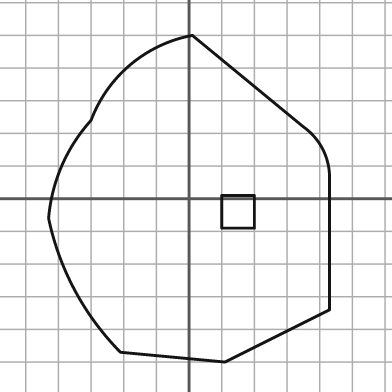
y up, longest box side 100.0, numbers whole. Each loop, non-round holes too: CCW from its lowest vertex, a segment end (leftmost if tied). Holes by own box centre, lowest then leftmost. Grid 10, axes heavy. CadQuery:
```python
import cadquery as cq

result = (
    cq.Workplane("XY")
    .moveTo(11.0, -50.0)
    .lineTo(43.0, -34.0)
    .lineTo(43.0, 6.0)
    .threePointArc((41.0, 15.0), (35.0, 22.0))
    .lineTo(1.0, 50.0)
    .threePointArc((-18.0, 41.0), (-30.0, 24.0))
    .threePointArc((-39.0, 10.0), (-43.0, -6.0))
    .threePointArc((-35.0, -28.0), (-21.0, -47.0))
    .close()
    .moveTo(10.0, -9.0)
    .lineTo(20.0, -9.0)
    .lineTo(20.0, 1.0)
    .lineTo(10.0, 1.0)
    .close()
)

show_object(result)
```